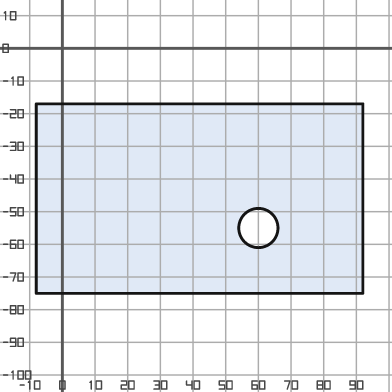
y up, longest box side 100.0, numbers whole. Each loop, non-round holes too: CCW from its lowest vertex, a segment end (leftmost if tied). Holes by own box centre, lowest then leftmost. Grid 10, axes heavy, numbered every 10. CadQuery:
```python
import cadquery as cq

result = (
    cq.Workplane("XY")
    .moveTo(-8.0, -75.0)
    .lineTo(92.0, -75.0)
    .lineTo(92.0, -17.0)
    .lineTo(-8.0, -17.0)
    .close()
    .moveTo(60.0, -55.0)
    .circle(6.0)
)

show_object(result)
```